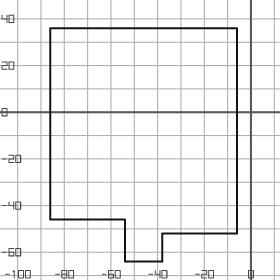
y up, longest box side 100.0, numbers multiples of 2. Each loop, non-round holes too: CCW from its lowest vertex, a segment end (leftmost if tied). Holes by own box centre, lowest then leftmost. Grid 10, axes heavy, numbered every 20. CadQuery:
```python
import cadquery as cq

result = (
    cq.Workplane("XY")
    .moveTo(-54.0, -64.0)
    .lineTo(-38.0, -64.0)
    .lineTo(-38.0, -52.0)
    .lineTo(-6.0, -52.0)
    .lineTo(-6.0, 36.0)
    .lineTo(-86.0, 36.0)
    .lineTo(-86.0, -46.0)
    .lineTo(-54.0, -46.0)
    .close()
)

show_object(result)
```